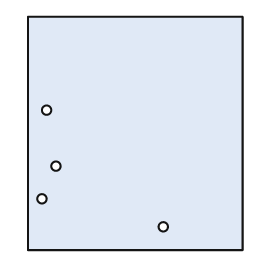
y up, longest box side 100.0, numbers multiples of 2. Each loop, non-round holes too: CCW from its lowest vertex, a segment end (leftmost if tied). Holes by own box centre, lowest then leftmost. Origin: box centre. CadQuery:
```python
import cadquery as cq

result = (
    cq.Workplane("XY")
    .moveTo(-46.0, -50.0)
    .lineTo(46.0, -50.0)
    .lineTo(46.0, 50.0)
    .lineTo(-46.0, 50.0)
    .close()
    .moveTo(12.0, -40.0)
    .circle(2.0)
    .moveTo(-40.0, -28.0)
    .circle(2.0)
    .moveTo(-34.0, -14.0)
    .circle(2.0)
    .moveTo(-38.0, 10.0)
    .circle(2.0)
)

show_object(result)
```